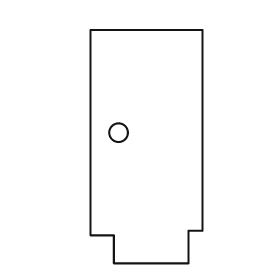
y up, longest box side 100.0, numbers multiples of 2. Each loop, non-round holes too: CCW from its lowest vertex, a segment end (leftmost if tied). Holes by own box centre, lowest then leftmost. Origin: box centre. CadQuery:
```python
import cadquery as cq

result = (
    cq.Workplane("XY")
    .moveTo(-14.0, -50.0)
    .lineTo(18.0, -50.0)
    .lineTo(18.0, -36.0)
    .lineTo(24.0, -36.0)
    .lineTo(24.0, 50.0)
    .lineTo(-24.0, 50.0)
    .lineTo(-24.0, -38.0)
    .lineTo(-14.0, -38.0)
    .close()
    .moveTo(-12.0, 6.0)
    .circle(4.0)
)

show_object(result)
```